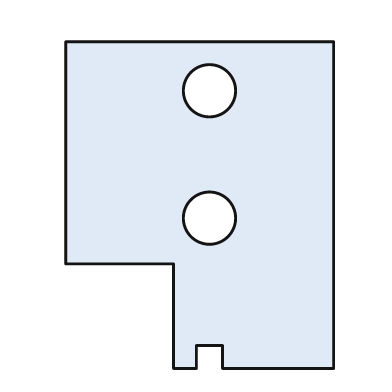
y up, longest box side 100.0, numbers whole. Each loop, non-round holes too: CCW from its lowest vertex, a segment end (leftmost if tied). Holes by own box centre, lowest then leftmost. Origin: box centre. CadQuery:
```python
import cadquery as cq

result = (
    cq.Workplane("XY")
    .moveTo(-8.0, -50.0)
    .lineTo(-1.0, -50.0)
    .lineTo(-1.0, -43.0)
    .lineTo(7.0, -43.0)
    .lineTo(7.0, -50.0)
    .lineTo(41.0, -50.0)
    .lineTo(41.0, 50.0)
    .lineTo(-41.0, 50.0)
    .lineTo(-41.0, -18.0)
    .lineTo(-8.0, -18.0)
    .close()
    .moveTo(3.0, -4.0)
    .circle(8.0)
    .moveTo(3.0, 35.0)
    .circle(8.0)
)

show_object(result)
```